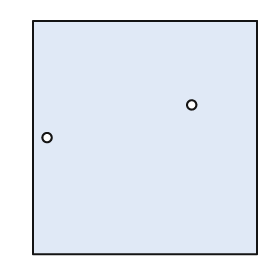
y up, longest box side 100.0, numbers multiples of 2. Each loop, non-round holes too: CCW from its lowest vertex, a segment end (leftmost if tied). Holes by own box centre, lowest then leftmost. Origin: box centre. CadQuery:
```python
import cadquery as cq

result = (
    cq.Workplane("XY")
    .moveTo(-48.0, -50.0)
    .lineTo(48.0, -50.0)
    .lineTo(48.0, 50.0)
    .lineTo(-48.0, 50.0)
    .close()
    .moveTo(-42.0, 0.0)
    .circle(2.0)
    .moveTo(20.0, 14.0)
    .circle(2.0)
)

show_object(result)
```